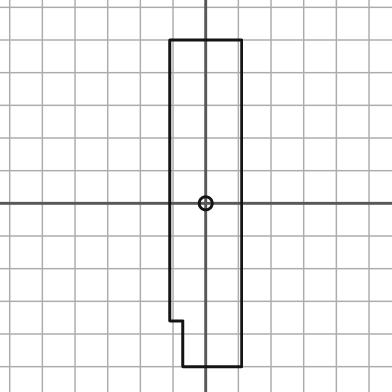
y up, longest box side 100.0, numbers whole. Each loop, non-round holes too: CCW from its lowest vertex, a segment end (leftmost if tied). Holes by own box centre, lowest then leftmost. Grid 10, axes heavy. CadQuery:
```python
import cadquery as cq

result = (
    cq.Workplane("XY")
    .moveTo(-7.0, -50.0)
    .lineTo(11.0, -50.0)
    .lineTo(11.0, 50.0)
    .lineTo(-11.0, 50.0)
    .lineTo(-11.0, -36.0)
    .lineTo(-7.0, -36.0)
    .close()
    .moveTo(0.0, 0.0)
    .circle(2.0)
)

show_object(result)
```